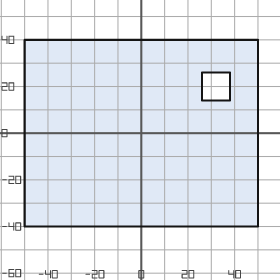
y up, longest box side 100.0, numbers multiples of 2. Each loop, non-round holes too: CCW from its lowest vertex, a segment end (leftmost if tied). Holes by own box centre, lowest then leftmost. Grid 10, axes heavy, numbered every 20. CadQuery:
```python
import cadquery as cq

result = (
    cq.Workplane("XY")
    .moveTo(-50.0, -40.0)
    .lineTo(50.0, -40.0)
    .lineTo(50.0, 40.0)
    .lineTo(-50.0, 40.0)
    .close()
    .moveTo(26.0, 14.0)
    .lineTo(38.0, 14.0)
    .lineTo(38.0, 26.0)
    .lineTo(26.0, 26.0)
    .close()
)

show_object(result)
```